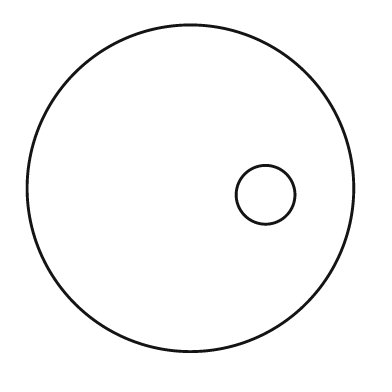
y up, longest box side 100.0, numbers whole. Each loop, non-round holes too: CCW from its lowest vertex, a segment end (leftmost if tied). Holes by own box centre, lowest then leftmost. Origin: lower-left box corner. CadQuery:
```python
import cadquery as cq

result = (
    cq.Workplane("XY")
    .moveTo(50.0, 50.0)
    .circle(50.0)
    .moveTo(73.0, 48.0)
    .circle(9.0)
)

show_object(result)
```